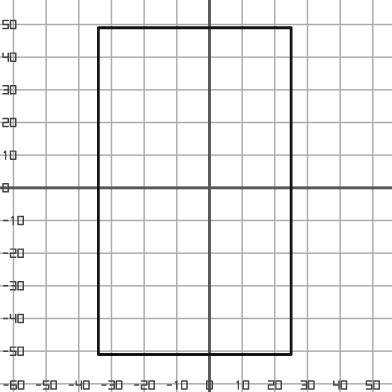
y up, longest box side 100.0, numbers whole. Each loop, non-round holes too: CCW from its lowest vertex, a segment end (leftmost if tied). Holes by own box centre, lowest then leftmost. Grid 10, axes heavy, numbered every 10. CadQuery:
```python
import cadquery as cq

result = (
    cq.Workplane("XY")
    .moveTo(-34.0, -51.0)
    .lineTo(25.0, -51.0)
    .lineTo(25.0, 49.0)
    .lineTo(-34.0, 49.0)
    .close()
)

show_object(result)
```